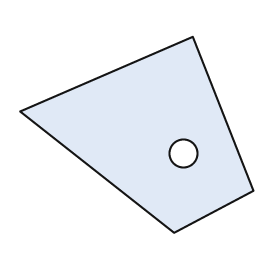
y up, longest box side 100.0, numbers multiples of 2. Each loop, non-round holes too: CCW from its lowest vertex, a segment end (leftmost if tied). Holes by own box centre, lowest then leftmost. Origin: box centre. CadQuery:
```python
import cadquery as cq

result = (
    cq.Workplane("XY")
    .moveTo(16.0, -42.0)
    .lineTo(50.0, -24.0)
    .lineTo(24.0, 42.0)
    .lineTo(-50.0, 10.0)
    .close()
    .moveTo(20.0, -8.0)
    .circle(6.0)
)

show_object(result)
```